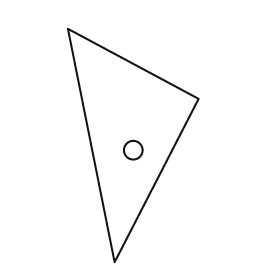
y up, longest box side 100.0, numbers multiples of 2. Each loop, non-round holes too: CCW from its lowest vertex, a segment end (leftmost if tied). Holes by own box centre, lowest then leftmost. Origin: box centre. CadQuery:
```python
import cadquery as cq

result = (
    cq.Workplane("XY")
    .moveTo(-8.0, -50.0)
    .lineTo(28.0, 20.0)
    .lineTo(-28.0, 50.0)
    .close()
    .moveTo(0.0, -2.0)
    .circle(4.0)
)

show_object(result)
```